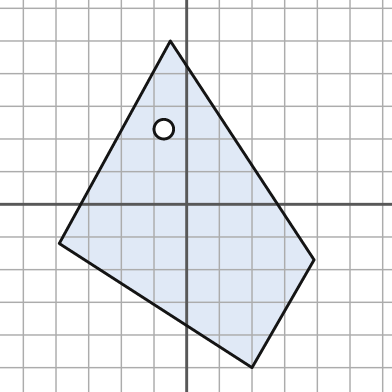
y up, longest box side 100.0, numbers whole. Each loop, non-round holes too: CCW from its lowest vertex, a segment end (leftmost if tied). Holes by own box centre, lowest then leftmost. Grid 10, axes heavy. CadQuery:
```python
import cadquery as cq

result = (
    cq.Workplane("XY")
    .moveTo(20.0, -50.0)
    .lineTo(39.0, -17.0)
    .lineTo(-5.0, 50.0)
    .lineTo(-39.0, -12.0)
    .close()
    .moveTo(-7.0, 23.0)
    .circle(3.0)
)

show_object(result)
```